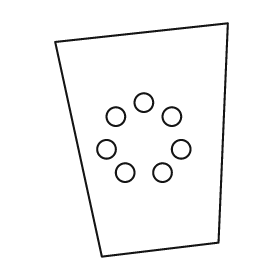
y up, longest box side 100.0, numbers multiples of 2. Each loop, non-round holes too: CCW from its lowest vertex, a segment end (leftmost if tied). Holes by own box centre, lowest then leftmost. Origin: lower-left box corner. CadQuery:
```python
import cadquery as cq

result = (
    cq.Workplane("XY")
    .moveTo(20.0, 0.0)
    .lineTo(70.0, 6.0)
    .lineTo(74.0, 100.0)
    .lineTo(0.0, 92.0)
    .close()
    .moveTo(30.0, 36.0)
    .circle(4.0)
    .moveTo(46.0, 36.0)
    .circle(4.0)
    .moveTo(22.0, 46.0)
    .circle(4.0)
    .moveTo(54.0, 46.0)
    .circle(4.0)
    .moveTo(26.0, 60.0)
    .circle(4.0)
    .moveTo(50.0, 60.0)
    .circle(4.0)
    .moveTo(38.0, 66.0)
    .circle(4.0)
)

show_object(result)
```